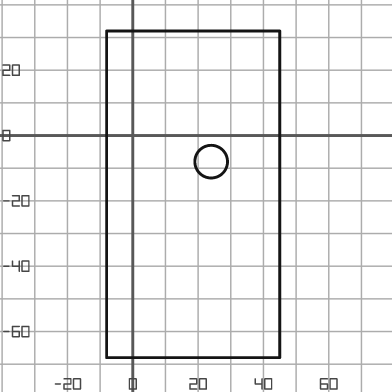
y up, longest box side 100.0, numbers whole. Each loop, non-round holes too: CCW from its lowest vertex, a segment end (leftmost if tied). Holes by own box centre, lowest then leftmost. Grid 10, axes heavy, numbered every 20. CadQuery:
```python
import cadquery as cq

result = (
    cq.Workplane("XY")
    .moveTo(-8.0, -68.0)
    .lineTo(45.0, -68.0)
    .lineTo(45.0, 32.0)
    .lineTo(-8.0, 32.0)
    .close()
    .moveTo(24.0, -8.0)
    .circle(5.0)
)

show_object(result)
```